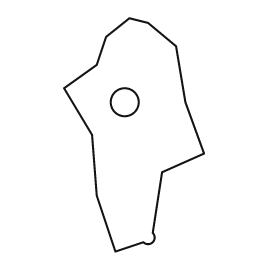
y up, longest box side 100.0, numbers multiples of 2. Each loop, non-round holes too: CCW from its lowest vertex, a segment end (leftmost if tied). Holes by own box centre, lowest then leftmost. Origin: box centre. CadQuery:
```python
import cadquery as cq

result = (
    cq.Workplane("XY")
    .moveTo(-8.0, -50.0)
    .lineTo(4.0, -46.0)
    .threePointArc((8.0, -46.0), (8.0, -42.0))
    .lineTo(12.0, -16.0)
    .lineTo(30.0, -8.0)
    .lineTo(22.0, 14.0)
    .lineTo(18.0, 38.0)
    .lineTo(6.0, 48.0)
    .lineTo(-2.0, 50.0)
    .lineTo(-12.0, 42.0)
    .lineTo(-16.0, 30.0)
    .lineTo(-30.0, 20.0)
    .lineTo(-18.0, 0.0)
    .lineTo(-16.0, -26.0)
    .close()
    .moveTo(-4.0, 14.0)
    .circle(6.0)
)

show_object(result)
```